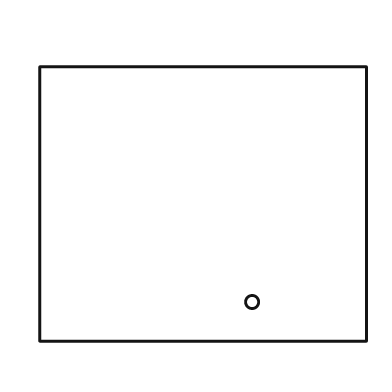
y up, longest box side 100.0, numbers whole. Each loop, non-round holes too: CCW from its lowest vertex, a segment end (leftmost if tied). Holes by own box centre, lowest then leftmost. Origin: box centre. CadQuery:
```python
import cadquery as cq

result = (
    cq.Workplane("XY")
    .moveTo(-50.0, -42.0)
    .lineTo(50.0, -42.0)
    .lineTo(50.0, 42.0)
    .lineTo(-50.0, 42.0)
    .close()
    .moveTo(15.0, -30.0)
    .circle(2.0)
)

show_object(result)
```